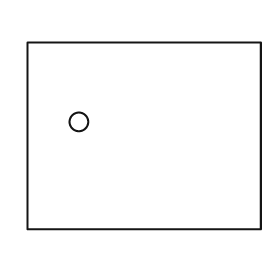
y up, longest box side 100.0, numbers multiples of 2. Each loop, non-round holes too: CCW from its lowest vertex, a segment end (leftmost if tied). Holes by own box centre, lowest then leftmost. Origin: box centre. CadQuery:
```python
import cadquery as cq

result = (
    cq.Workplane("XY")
    .moveTo(-50.0, -40.0)
    .lineTo(50.0, -40.0)
    .lineTo(50.0, 40.0)
    .lineTo(-50.0, 40.0)
    .close()
    .moveTo(-28.0, 6.0)
    .circle(4.0)
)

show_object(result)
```